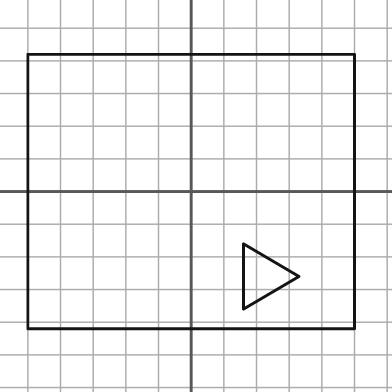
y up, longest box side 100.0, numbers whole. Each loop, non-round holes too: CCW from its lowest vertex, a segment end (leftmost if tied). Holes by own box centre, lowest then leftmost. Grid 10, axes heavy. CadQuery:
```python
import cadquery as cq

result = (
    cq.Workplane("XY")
    .moveTo(-50.0, -42.0)
    .lineTo(50.0, -42.0)
    .lineTo(50.0, 42.0)
    .lineTo(-50.0, 42.0)
    .close()
    .moveTo(16.0, -36.0)
    .lineTo(33.0, -26.0)
    .lineTo(16.0, -16.0)
    .close()
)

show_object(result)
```